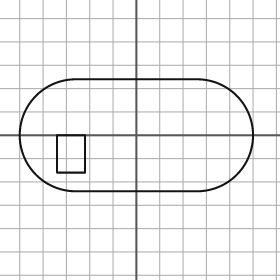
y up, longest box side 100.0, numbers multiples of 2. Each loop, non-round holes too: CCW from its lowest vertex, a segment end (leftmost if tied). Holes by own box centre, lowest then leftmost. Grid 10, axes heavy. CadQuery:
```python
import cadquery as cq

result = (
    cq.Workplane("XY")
    .moveTo(-26.0, -24.0)
    .lineTo(26.0, -24.0)
    .threePointArc((50.0, 0.0), (26.0, 24.0))
    .lineTo(-26.0, 24.0)
    .threePointArc((-50.0, 0.0), (-26.0, -24.0))
    .close()
    .moveTo(-34.0, -16.0)
    .lineTo(-22.0, -16.0)
    .lineTo(-22.0, 0.0)
    .lineTo(-34.0, 0.0)
    .close()
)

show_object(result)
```